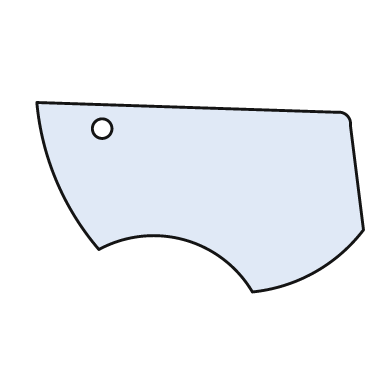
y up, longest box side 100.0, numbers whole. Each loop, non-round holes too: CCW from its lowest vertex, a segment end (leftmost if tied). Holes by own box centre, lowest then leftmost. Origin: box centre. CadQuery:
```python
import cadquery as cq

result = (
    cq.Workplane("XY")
    .moveTo(16.0, -29.0)
    .threePointArc((35.0, -23.0), (50.0, -10.0))
    .lineTo(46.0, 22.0)
    .threePointArc((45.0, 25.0), (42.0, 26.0))
    .lineTo(-50.0, 29.0)
    .threePointArc((-44.0, 5.0), (-31.0, -16.0))
    .threePointArc((-5.0, -13.0), (16.0, -29.0))
    .close()
    .moveTo(-30.0, 21.0)
    .circle(3.0)
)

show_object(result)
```